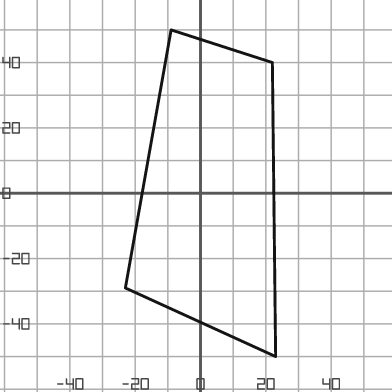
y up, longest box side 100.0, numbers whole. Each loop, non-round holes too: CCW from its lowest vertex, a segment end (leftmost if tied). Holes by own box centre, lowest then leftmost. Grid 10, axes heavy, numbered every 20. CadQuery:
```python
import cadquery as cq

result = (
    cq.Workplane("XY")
    .moveTo(23.0, -50.0)
    .lineTo(22.0, 40.0)
    .lineTo(-9.0, 50.0)
    .lineTo(-23.0, -29.0)
    .close()
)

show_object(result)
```